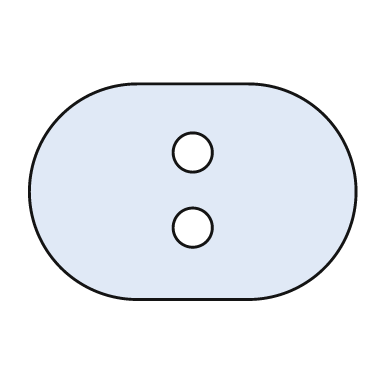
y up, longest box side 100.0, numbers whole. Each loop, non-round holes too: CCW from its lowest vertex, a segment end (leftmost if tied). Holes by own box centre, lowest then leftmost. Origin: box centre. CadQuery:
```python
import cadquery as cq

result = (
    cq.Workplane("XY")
    .moveTo(-17.0, -33.0)
    .lineTo(17.0, -33.0)
    .threePointArc((50.0, 0.0), (17.0, 33.0))
    .lineTo(-17.0, 33.0)
    .threePointArc((-50.0, 0.0), (-17.0, -33.0))
    .close()
    .moveTo(0.0, -11.0)
    .circle(6.0)
    .moveTo(0.0, 12.0)
    .circle(6.0)
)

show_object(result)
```